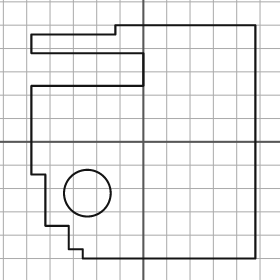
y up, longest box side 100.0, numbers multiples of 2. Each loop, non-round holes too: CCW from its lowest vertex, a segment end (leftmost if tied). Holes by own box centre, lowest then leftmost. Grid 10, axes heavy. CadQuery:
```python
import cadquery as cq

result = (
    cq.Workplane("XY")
    .moveTo(-26.0, -50.0)
    .lineTo(48.0, -50.0)
    .lineTo(48.0, 50.0)
    .lineTo(-12.0, 50.0)
    .lineTo(-12.0, 46.0)
    .lineTo(-48.0, 46.0)
    .lineTo(-48.0, 38.0)
    .lineTo(0.0, 38.0)
    .lineTo(0.0, 24.0)
    .lineTo(-48.0, 24.0)
    .lineTo(-48.0, -14.0)
    .lineTo(-42.0, -14.0)
    .lineTo(-42.0, -36.0)
    .lineTo(-32.0, -36.0)
    .lineTo(-32.0, -46.0)
    .lineTo(-26.0, -46.0)
    .close()
    .moveTo(-24.0, -22.0)
    .circle(10.0)
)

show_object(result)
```